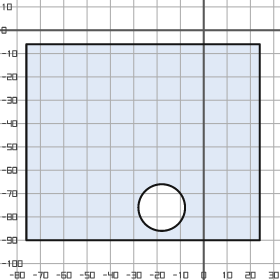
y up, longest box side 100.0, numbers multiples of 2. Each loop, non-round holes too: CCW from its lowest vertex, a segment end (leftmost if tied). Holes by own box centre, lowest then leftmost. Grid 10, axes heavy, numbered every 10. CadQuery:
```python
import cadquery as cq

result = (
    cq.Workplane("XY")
    .moveTo(-76.0, -90.0)
    .lineTo(24.0, -90.0)
    .lineTo(24.0, -6.0)
    .lineTo(-76.0, -6.0)
    .close()
    .moveTo(-18.0, -76.0)
    .circle(10.0)
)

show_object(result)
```